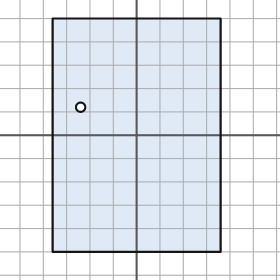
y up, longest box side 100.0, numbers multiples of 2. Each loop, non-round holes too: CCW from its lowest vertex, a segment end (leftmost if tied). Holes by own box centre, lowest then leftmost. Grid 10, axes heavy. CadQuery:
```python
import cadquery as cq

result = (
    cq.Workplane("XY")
    .moveTo(-36.0, -50.0)
    .lineTo(36.0, -50.0)
    .lineTo(36.0, 50.0)
    .lineTo(-36.0, 50.0)
    .close()
    .moveTo(-24.0, 12.0)
    .circle(2.0)
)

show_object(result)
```